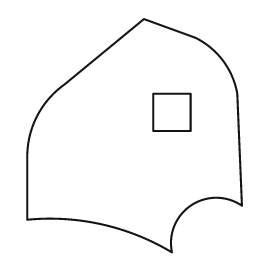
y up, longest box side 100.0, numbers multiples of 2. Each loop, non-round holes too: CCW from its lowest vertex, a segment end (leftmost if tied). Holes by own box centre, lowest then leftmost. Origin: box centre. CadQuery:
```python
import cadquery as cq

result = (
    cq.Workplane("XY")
    .moveTo(16.0, -50.0)
    .threePointArc((24.0, -30.0), (46.0, -30.0))
    .lineTo(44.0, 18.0)
    .threePointArc((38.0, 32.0), (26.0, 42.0))
    .lineTo(4.0, 50.0)
    .lineTo(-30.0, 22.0)
    .threePointArc((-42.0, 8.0), (-46.0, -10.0))
    .lineTo(-46.0, -36.0)
    .threePointArc((-14.0, -38.0), (16.0, -50.0))
    .close()
    .moveTo(8.0, 2.0)
    .lineTo(24.0, 2.0)
    .lineTo(24.0, 18.0)
    .lineTo(8.0, 18.0)
    .close()
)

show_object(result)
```